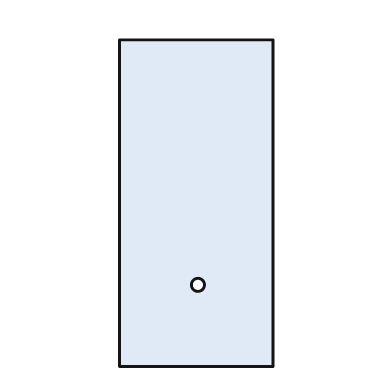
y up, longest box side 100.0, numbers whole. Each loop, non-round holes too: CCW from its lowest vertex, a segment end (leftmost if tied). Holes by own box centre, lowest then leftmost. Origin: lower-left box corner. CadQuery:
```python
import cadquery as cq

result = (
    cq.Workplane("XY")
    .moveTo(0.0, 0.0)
    .lineTo(47.0, 0.0)
    .lineTo(47.0, 100.0)
    .lineTo(0.0, 100.0)
    .close()
    .moveTo(24.0, 25.0)
    .circle(2.0)
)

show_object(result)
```